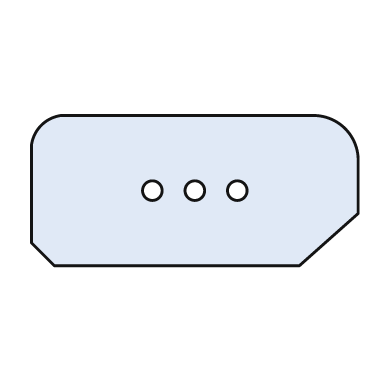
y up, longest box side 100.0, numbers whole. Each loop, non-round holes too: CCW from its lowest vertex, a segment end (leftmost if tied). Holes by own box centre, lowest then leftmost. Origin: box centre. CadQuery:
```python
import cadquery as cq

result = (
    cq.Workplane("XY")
    .moveTo(-43.0, -23.0)
    .lineTo(32.0, -23.0)
    .lineTo(50.0, -7.0)
    .lineTo(50.0, 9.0)
    .threePointArc((46.0, 19.0), (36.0, 23.0))
    .lineTo(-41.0, 23.0)
    .threePointArc((-47.0, 20.0), (-50.0, 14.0))
    .lineTo(-50.0, -16.0)
    .close()
    .moveTo(-13.0, 0.0)
    .circle(3.0)
    .moveTo(0.0, 0.0)
    .circle(3.0)
    .moveTo(13.0, 0.0)
    .circle(3.0)
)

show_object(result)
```